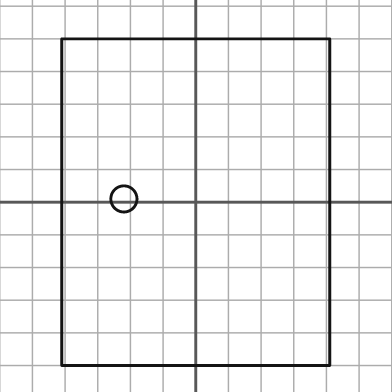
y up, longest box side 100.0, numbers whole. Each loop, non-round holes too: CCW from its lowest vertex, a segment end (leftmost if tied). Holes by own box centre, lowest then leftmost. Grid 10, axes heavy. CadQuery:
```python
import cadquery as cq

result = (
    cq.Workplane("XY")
    .moveTo(-41.0, -50.0)
    .lineTo(41.0, -50.0)
    .lineTo(41.0, 50.0)
    .lineTo(-41.0, 50.0)
    .close()
    .moveTo(-22.0, 1.0)
    .circle(4.0)
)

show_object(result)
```